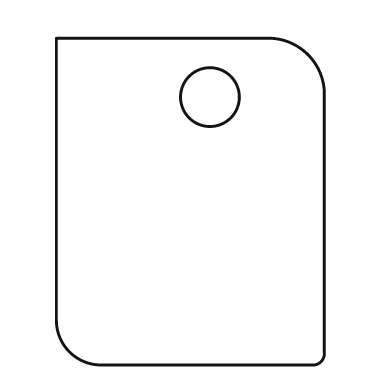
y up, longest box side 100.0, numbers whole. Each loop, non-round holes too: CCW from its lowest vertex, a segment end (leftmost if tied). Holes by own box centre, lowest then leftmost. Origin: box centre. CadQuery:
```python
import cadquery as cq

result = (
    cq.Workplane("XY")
    .moveTo(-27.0, -50.0)
    .lineTo(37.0, -50.0)
    .threePointArc((40.0, -49.0), (41.0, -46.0))
    .lineTo(41.0, 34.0)
    .threePointArc((36.0, 45.0), (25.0, 50.0))
    .lineTo(-41.0, 50.0)
    .lineTo(-41.0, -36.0)
    .threePointArc((-37.0, -46.0), (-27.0, -50.0))
    .close()
    .moveTo(6.0, 32.0)
    .circle(9.0)
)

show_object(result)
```